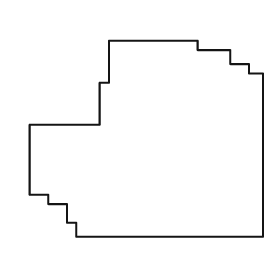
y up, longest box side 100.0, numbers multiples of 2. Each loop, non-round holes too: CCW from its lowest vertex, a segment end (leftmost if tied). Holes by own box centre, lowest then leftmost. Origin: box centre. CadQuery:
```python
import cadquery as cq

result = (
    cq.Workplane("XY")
    .moveTo(-30.0, -42.0)
    .lineTo(50.0, -42.0)
    .lineTo(50.0, 28.0)
    .lineTo(44.0, 28.0)
    .lineTo(44.0, 32.0)
    .lineTo(36.0, 32.0)
    .lineTo(36.0, 38.0)
    .lineTo(22.0, 38.0)
    .lineTo(22.0, 42.0)
    .lineTo(-16.0, 42.0)
    .lineTo(-16.0, 24.0)
    .lineTo(-20.0, 24.0)
    .lineTo(-20.0, 6.0)
    .lineTo(-50.0, 6.0)
    .lineTo(-50.0, -24.0)
    .lineTo(-42.0, -24.0)
    .lineTo(-42.0, -28.0)
    .lineTo(-34.0, -28.0)
    .lineTo(-34.0, -36.0)
    .lineTo(-30.0, -36.0)
    .close()
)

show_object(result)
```